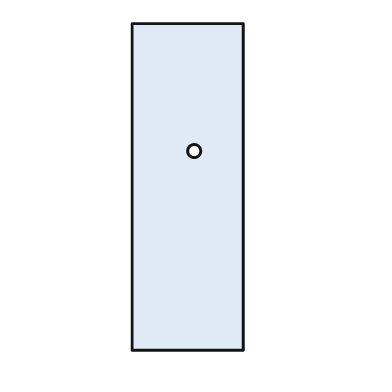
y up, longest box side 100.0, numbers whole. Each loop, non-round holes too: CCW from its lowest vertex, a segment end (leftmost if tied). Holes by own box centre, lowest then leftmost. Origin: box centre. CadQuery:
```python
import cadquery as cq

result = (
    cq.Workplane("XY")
    .moveTo(-17.0, -50.0)
    .lineTo(17.0, -50.0)
    .lineTo(17.0, 50.0)
    .lineTo(-17.0, 50.0)
    .close()
    .moveTo(2.0, 11.0)
    .circle(2.0)
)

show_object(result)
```